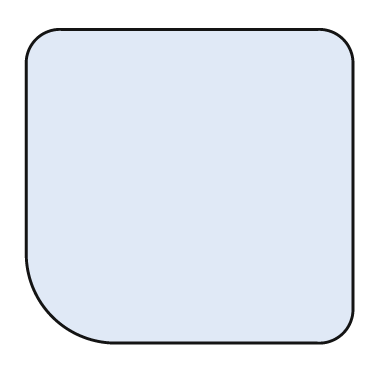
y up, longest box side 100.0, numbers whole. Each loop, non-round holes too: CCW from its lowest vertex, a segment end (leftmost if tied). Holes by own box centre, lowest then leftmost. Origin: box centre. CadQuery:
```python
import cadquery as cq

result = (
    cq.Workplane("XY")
    .moveTo(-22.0, -48.0)
    .lineTo(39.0, -48.0)
    .threePointArc((47.0, -45.0), (50.0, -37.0))
    .lineTo(50.0, 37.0)
    .threePointArc((47.0, 45.0), (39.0, 48.0))
    .lineTo(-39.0, 48.0)
    .threePointArc((-47.0, 45.0), (-50.0, 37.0))
    .lineTo(-50.0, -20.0)
    .threePointArc((-42.0, -40.0), (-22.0, -48.0))
    .close()
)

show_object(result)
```